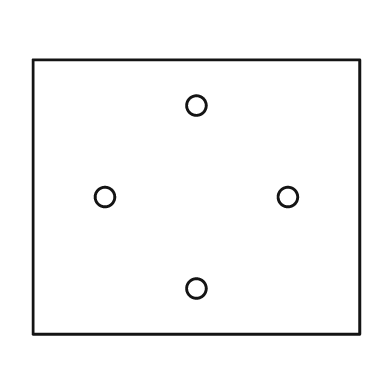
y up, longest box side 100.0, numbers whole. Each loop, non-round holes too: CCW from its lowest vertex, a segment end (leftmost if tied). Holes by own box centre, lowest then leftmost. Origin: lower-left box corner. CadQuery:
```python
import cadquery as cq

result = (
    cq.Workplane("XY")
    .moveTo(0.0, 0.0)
    .lineTo(100.0, 0.0)
    .lineTo(100.0, 84.0)
    .lineTo(0.0, 84.0)
    .close()
    .moveTo(50.0, 14.0)
    .circle(3.0)
    .moveTo(22.0, 42.0)
    .circle(3.0)
    .moveTo(78.0, 42.0)
    .circle(3.0)
    .moveTo(50.0, 70.0)
    .circle(3.0)
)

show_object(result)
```